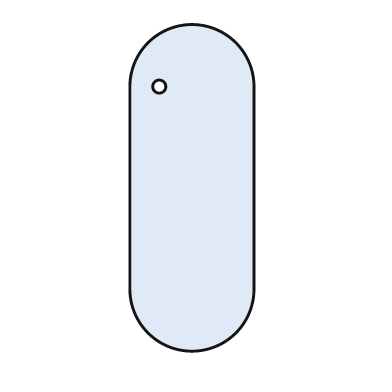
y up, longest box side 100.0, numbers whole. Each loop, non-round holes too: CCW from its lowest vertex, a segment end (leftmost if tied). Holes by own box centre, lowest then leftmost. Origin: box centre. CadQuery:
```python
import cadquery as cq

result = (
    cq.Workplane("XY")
    .moveTo(-19.0, -31.0)
    .threePointArc((0.0, -50.0), (19.0, -31.0))
    .lineTo(19.0, 31.0)
    .threePointArc((0.0, 50.0), (-19.0, 31.0))
    .close()
    .moveTo(-10.0, 31.0)
    .circle(2.0)
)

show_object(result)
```